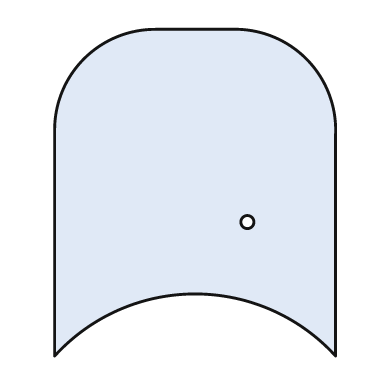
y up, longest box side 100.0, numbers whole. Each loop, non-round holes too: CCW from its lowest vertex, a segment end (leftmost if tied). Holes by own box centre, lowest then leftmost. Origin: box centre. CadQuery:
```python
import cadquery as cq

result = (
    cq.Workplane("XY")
    .moveTo(-43.0, -50.0)
    .threePointArc((0.0, -31.0), (43.0, -50.0))
    .lineTo(43.0, 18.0)
    .threePointArc((34.0, 41.0), (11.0, 50.0))
    .lineTo(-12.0, 50.0)
    .threePointArc((-34.0, 41.0), (-43.0, 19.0))
    .close()
    .moveTo(16.0, -9.0)
    .circle(2.0)
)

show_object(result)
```